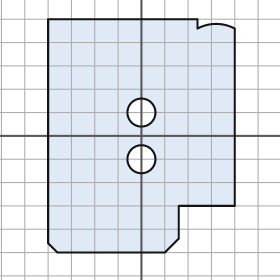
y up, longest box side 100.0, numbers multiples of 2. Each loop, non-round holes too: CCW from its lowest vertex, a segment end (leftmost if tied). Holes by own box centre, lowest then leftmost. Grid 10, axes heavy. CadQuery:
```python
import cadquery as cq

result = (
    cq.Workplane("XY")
    .moveTo(-36.0, -50.0)
    .lineTo(10.0, -50.0)
    .lineTo(16.0, -44.0)
    .lineTo(16.0, -30.0)
    .lineTo(40.0, -30.0)
    .lineTo(40.0, 46.0)
    .threePointArc((32.0, 48.0), (24.0, 46.0))
    .lineTo(24.0, 50.0)
    .lineTo(-40.0, 50.0)
    .lineTo(-40.0, -46.0)
    .close()
    .moveTo(0.0, -10.0)
    .circle(6.0)
    .moveTo(0.0, 10.0)
    .circle(6.0)
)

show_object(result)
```